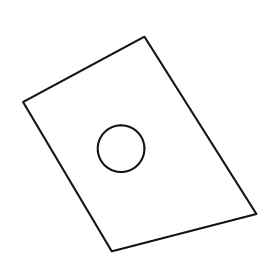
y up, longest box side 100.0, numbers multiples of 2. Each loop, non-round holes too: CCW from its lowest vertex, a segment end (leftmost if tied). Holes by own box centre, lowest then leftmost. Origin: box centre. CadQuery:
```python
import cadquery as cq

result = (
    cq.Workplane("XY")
    .moveTo(-12.0, -46.0)
    .lineTo(50.0, -30.0)
    .lineTo(2.0, 46.0)
    .lineTo(-50.0, 18.0)
    .close()
    .moveTo(-8.0, -2.0)
    .circle(10.0)
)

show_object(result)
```